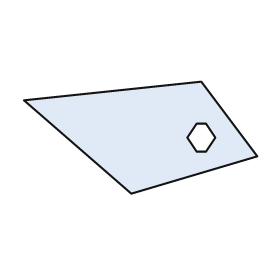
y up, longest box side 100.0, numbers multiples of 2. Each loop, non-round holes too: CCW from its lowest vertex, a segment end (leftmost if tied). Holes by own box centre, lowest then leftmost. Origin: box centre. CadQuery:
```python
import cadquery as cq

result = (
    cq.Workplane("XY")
    .moveTo(-4.0, -24.0)
    .lineTo(50.0, -8.0)
    .lineTo(26.0, 24.0)
    .lineTo(-50.0, 16.0)
    .close()
    .moveTo(24.0, -6.0)
    .lineTo(28.0, -6.0)
    .lineTo(32.0, 0.0)
    .lineTo(28.0, 6.0)
    .lineTo(24.0, 6.0)
    .lineTo(20.0, 0.0)
    .close()
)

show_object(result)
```